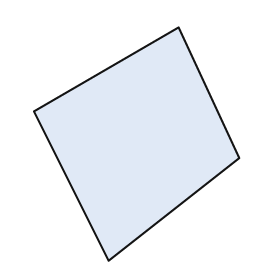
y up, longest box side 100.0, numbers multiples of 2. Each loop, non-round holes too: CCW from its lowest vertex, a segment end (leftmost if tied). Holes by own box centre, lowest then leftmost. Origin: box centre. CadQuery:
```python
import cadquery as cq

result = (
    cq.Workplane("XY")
    .moveTo(-12.0, -50.0)
    .lineTo(44.0, -6.0)
    .lineTo(18.0, 50.0)
    .lineTo(-44.0, 14.0)
    .close()
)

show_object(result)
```